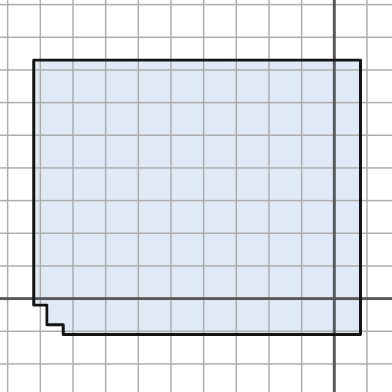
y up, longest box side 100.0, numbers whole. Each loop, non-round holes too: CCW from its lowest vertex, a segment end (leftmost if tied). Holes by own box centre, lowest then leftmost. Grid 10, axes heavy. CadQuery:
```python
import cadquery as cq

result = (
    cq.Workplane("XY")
    .moveTo(-83.0, -11.0)
    .lineTo(8.0, -11.0)
    .lineTo(8.0, 73.0)
    .lineTo(-92.0, 73.0)
    .lineTo(-92.0, -2.0)
    .lineTo(-88.0, -2.0)
    .lineTo(-88.0, -8.0)
    .lineTo(-83.0, -8.0)
    .close()
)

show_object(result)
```